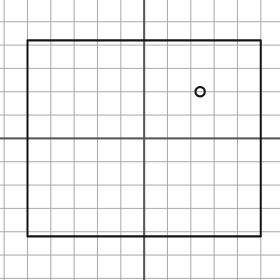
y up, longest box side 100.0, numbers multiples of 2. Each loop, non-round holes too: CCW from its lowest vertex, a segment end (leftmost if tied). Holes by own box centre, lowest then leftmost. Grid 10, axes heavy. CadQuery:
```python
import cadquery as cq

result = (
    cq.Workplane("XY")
    .moveTo(-50.0, -42.0)
    .lineTo(50.0, -42.0)
    .lineTo(50.0, 42.0)
    .lineTo(-50.0, 42.0)
    .close()
    .moveTo(24.0, 20.0)
    .circle(2.0)
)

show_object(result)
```